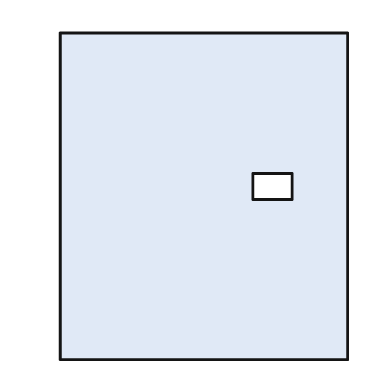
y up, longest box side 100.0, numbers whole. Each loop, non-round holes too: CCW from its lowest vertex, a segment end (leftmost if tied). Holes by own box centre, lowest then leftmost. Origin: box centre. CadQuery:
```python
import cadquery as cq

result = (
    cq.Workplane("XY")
    .moveTo(-44.0, -50.0)
    .lineTo(44.0, -50.0)
    .lineTo(44.0, 50.0)
    .lineTo(-44.0, 50.0)
    .close()
    .moveTo(15.0, -1.0)
    .lineTo(27.0, -1.0)
    .lineTo(27.0, 7.0)
    .lineTo(15.0, 7.0)
    .close()
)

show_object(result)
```